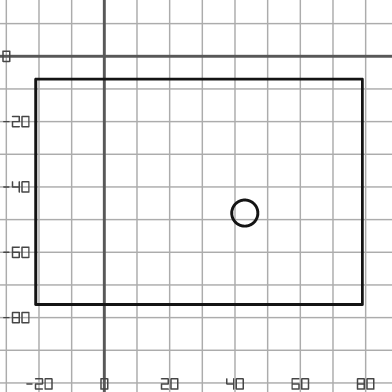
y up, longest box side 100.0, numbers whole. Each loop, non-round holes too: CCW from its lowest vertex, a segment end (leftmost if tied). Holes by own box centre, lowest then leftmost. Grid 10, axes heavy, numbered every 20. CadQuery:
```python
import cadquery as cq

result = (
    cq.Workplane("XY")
    .moveTo(-21.0, -76.0)
    .lineTo(79.0, -76.0)
    .lineTo(79.0, -7.0)
    .lineTo(-21.0, -7.0)
    .close()
    .moveTo(43.0, -48.0)
    .circle(4.0)
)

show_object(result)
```